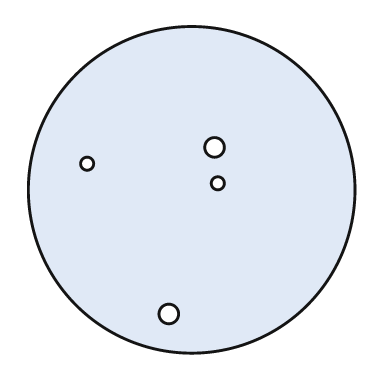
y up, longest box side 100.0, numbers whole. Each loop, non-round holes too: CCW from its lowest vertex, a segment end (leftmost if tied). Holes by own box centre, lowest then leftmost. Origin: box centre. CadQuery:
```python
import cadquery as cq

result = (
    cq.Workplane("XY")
    .moveTo(0.0, 0.0)
    .circle(50.0)
    .moveTo(-7.0, -38.0)
    .circle(3.0)
    .moveTo(8.0, 2.0)
    .circle(2.0)
    .moveTo(-32.0, 8.0)
    .circle(2.0)
    .moveTo(7.0, 13.0)
    .circle(3.0)
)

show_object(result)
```